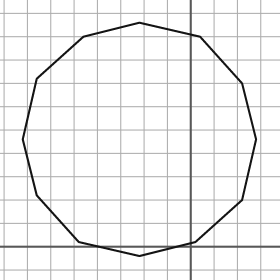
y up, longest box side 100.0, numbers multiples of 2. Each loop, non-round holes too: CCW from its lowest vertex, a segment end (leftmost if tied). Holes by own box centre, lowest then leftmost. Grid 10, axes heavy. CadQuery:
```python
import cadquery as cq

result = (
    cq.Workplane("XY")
    .moveTo(-22.0, -4.0)
    .lineTo(2.0, 2.0)
    .lineTo(22.0, 20.0)
    .lineTo(28.0, 46.0)
    .lineTo(22.0, 70.0)
    .lineTo(4.0, 90.0)
    .lineTo(-22.0, 96.0)
    .lineTo(-46.0, 90.0)
    .lineTo(-66.0, 72.0)
    .lineTo(-72.0, 46.0)
    .lineTo(-66.0, 22.0)
    .lineTo(-48.0, 2.0)
    .close()
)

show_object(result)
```